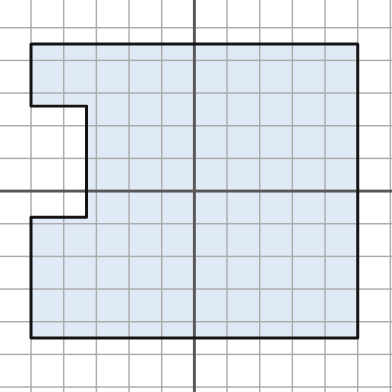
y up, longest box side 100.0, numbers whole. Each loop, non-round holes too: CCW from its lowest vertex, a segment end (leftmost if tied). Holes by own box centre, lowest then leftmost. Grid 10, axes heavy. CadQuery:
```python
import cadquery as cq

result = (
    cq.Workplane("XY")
    .moveTo(-50.0, -45.0)
    .lineTo(50.0, -45.0)
    .lineTo(50.0, 45.0)
    .lineTo(-50.0, 45.0)
    .lineTo(-50.0, 26.0)
    .lineTo(-33.0, 26.0)
    .lineTo(-33.0, -8.0)
    .lineTo(-50.0, -8.0)
    .close()
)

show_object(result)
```